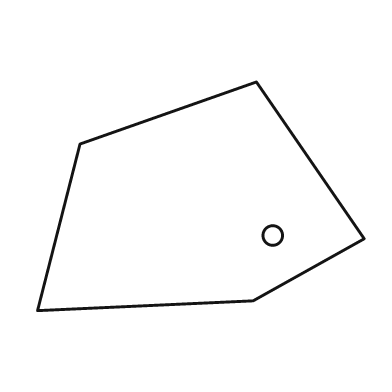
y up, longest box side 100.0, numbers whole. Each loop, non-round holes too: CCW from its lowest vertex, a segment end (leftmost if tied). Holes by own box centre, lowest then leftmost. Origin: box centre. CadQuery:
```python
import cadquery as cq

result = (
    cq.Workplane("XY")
    .moveTo(-50.0, -35.0)
    .lineTo(16.0, -32.0)
    .lineTo(50.0, -13.0)
    .lineTo(17.0, 35.0)
    .lineTo(-37.0, 16.0)
    .close()
    .moveTo(22.0, -12.0)
    .circle(3.0)
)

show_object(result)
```